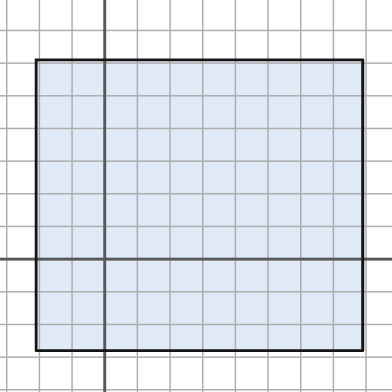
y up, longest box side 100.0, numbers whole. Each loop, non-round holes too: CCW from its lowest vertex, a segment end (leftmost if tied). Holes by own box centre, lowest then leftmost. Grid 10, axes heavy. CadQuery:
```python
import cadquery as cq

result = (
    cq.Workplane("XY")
    .moveTo(-21.0, -28.0)
    .lineTo(79.0, -28.0)
    .lineTo(79.0, 61.0)
    .lineTo(-21.0, 61.0)
    .close()
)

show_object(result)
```